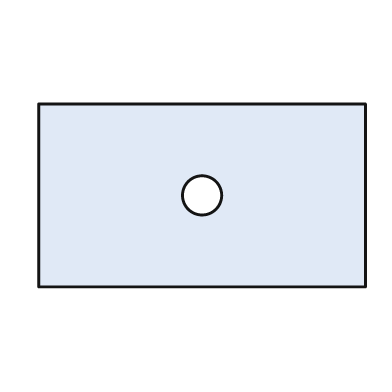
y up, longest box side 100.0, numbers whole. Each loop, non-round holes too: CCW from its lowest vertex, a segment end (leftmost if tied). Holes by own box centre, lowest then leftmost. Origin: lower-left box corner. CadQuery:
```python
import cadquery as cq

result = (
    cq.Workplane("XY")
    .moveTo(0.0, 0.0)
    .lineTo(100.0, 0.0)
    .lineTo(100.0, 56.0)
    .lineTo(0.0, 56.0)
    .close()
    .moveTo(50.0, 28.0)
    .circle(6.0)
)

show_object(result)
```